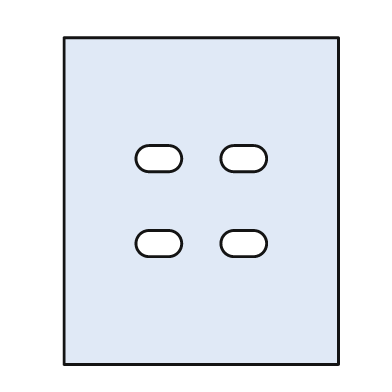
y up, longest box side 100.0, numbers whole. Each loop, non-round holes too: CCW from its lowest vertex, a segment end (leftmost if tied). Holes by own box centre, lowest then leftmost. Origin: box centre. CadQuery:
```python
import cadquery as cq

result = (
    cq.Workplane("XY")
    .moveTo(-42.0, -50.0)
    .lineTo(42.0, -50.0)
    .lineTo(42.0, 50.0)
    .lineTo(-42.0, 50.0)
    .close()
    .moveTo(-16.0, -17.0)
    .lineTo(-10.0, -17.0)
    .threePointArc((-6.0, -13.0), (-10.0, -9.0))
    .lineTo(-16.0, -9.0)
    .threePointArc((-20.0, -13.0), (-16.0, -17.0))
    .close()
    .moveTo(10.0, -17.0)
    .lineTo(16.0, -17.0)
    .threePointArc((20.0, -13.0), (16.0, -9.0))
    .lineTo(10.0, -9.0)
    .threePointArc((6.0, -13.0), (10.0, -17.0))
    .close()
    .moveTo(-16.0, 9.0)
    .lineTo(-10.0, 9.0)
    .threePointArc((-6.0, 13.0), (-10.0, 17.0))
    .lineTo(-16.0, 17.0)
    .threePointArc((-20.0, 13.0), (-16.0, 9.0))
    .close()
    .moveTo(10.0, 9.0)
    .lineTo(16.0, 9.0)
    .threePointArc((20.0, 13.0), (16.0, 17.0))
    .lineTo(10.0, 17.0)
    .threePointArc((6.0, 13.0), (10.0, 9.0))
    .close()
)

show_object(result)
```